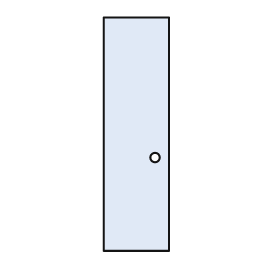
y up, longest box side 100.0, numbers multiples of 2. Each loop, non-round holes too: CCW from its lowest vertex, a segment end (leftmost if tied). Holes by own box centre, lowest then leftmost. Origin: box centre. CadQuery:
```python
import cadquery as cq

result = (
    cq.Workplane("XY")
    .moveTo(-14.0, -50.0)
    .lineTo(14.0, -50.0)
    .lineTo(14.0, 50.0)
    .lineTo(-14.0, 50.0)
    .close()
    .moveTo(8.0, -10.0)
    .circle(2.0)
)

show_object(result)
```